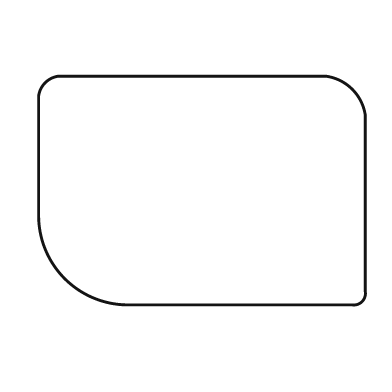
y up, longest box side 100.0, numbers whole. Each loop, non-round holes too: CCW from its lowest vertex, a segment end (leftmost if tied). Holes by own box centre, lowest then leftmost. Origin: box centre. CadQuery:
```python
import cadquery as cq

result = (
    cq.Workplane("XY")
    .moveTo(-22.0, -35.0)
    .lineTo(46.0, -35.0)
    .threePointArc((49.0, -34.0), (50.0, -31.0))
    .lineTo(50.0, 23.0)
    .threePointArc((46.0, 31.0), (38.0, 35.0))
    .lineTo(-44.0, 35.0)
    .threePointArc((-48.0, 33.0), (-50.0, 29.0))
    .lineTo(-50.0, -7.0)
    .threePointArc((-42.0, -27.0), (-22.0, -35.0))
    .close()
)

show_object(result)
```